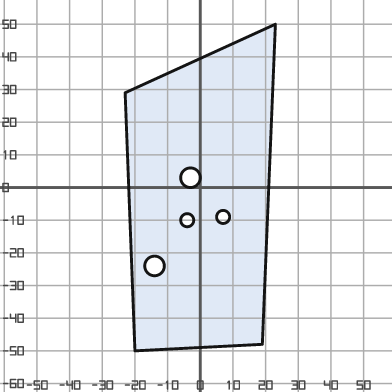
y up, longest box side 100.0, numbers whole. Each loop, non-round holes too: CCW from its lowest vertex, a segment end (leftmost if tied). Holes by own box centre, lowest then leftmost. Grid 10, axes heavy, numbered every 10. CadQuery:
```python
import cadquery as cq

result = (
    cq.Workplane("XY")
    .moveTo(-20.0, -50.0)
    .lineTo(19.0, -48.0)
    .lineTo(23.0, 50.0)
    .lineTo(-23.0, 29.0)
    .close()
    .moveTo(-14.0, -24.0)
    .circle(3.0)
    .moveTo(-4.0, -10.0)
    .circle(2.0)
    .moveTo(7.0, -9.0)
    .circle(2.0)
    .moveTo(-3.0, 3.0)
    .circle(3.0)
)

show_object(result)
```